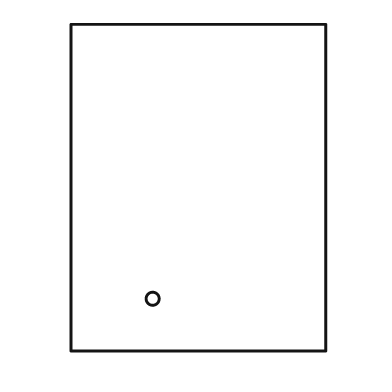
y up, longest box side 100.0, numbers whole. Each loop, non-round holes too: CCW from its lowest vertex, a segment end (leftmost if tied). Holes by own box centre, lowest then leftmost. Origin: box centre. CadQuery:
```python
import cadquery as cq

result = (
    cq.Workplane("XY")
    .moveTo(-39.0, -50.0)
    .lineTo(39.0, -50.0)
    .lineTo(39.0, 50.0)
    .lineTo(-39.0, 50.0)
    .close()
    .moveTo(-14.0, -34.0)
    .circle(2.0)
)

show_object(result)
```